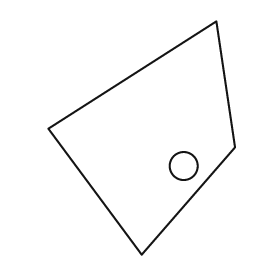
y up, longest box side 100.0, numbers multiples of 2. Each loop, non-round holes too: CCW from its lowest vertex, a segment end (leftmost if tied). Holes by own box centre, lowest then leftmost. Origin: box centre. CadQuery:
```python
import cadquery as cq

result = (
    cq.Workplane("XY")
    .moveTo(0.0, -50.0)
    .lineTo(40.0, -4.0)
    .lineTo(32.0, 50.0)
    .lineTo(-40.0, 4.0)
    .close()
    .moveTo(18.0, -12.0)
    .circle(6.0)
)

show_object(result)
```